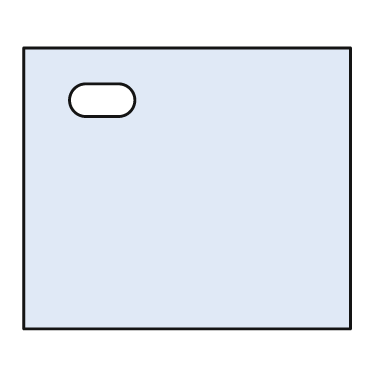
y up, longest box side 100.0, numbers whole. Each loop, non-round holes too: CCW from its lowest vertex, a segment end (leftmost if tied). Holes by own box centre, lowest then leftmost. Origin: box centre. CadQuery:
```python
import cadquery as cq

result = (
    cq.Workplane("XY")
    .moveTo(-50.0, -43.0)
    .lineTo(50.0, -43.0)
    .lineTo(50.0, 43.0)
    .lineTo(-50.0, 43.0)
    .close()
    .moveTo(-31.0, 22.0)
    .lineTo(-21.0, 22.0)
    .threePointArc((-16.0, 27.0), (-21.0, 32.0))
    .lineTo(-31.0, 32.0)
    .threePointArc((-36.0, 27.0), (-31.0, 22.0))
    .close()
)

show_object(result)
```